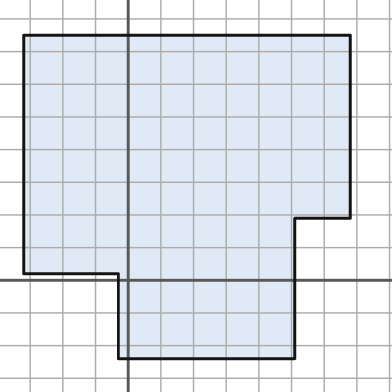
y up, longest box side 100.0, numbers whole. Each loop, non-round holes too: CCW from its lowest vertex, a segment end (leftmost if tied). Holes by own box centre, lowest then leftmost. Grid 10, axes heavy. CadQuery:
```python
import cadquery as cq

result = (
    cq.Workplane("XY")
    .moveTo(-3.0, -24.0)
    .lineTo(51.0, -24.0)
    .lineTo(51.0, 19.0)
    .lineTo(68.0, 19.0)
    .lineTo(68.0, 75.0)
    .lineTo(-32.0, 75.0)
    .lineTo(-32.0, 2.0)
    .lineTo(-3.0, 2.0)
    .close()
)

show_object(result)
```